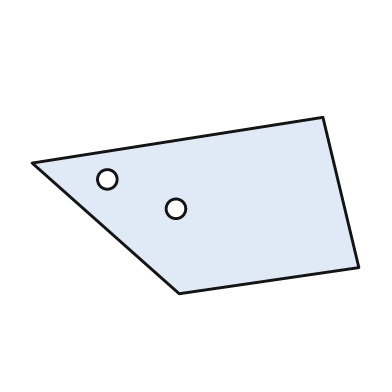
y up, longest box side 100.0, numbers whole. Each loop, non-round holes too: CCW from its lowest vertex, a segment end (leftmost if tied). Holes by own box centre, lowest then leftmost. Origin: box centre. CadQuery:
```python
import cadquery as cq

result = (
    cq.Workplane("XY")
    .moveTo(-5.0, -27.0)
    .lineTo(50.0, -19.0)
    .lineTo(39.0, 27.0)
    .lineTo(-50.0, 13.0)
    .close()
    .moveTo(-6.0, -1.0)
    .circle(3.0)
    .moveTo(-27.0, 8.0)
    .circle(3.0)
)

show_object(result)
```